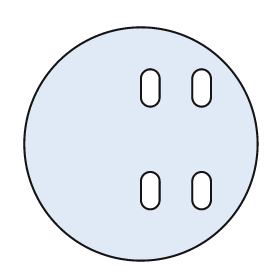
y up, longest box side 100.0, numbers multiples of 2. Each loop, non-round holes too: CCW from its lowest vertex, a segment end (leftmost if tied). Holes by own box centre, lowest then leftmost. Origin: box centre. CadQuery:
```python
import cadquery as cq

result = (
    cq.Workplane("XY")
    .moveTo(0.0, 0.0)
    .circle(50.0)
    .moveTo(0.0, -24.0)
    .threePointArc((4.0, -28.0), (8.0, -24.0))
    .lineTo(8.0, -16.0)
    .threePointArc((4.0, -12.0), (0.0, -16.0))
    .close()
    .moveTo(22.0, -24.0)
    .threePointArc((26.0, -28.0), (30.0, -24.0))
    .lineTo(30.0, -16.0)
    .threePointArc((26.0, -12.0), (22.0, -16.0))
    .close()
    .moveTo(0.0, 20.0)
    .threePointArc((4.0, 16.0), (8.0, 20.0))
    .lineTo(8.0, 28.0)
    .threePointArc((4.0, 32.0), (0.0, 28.0))
    .close()
    .moveTo(22.0, 20.0)
    .threePointArc((26.0, 16.0), (30.0, 20.0))
    .lineTo(30.0, 28.0)
    .threePointArc((26.0, 32.0), (22.0, 28.0))
    .close()
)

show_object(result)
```